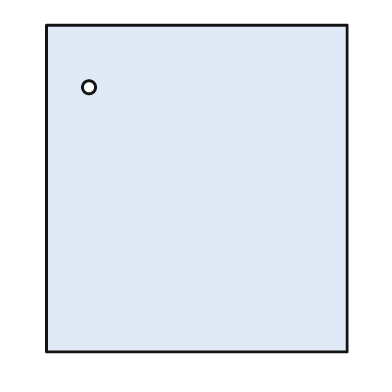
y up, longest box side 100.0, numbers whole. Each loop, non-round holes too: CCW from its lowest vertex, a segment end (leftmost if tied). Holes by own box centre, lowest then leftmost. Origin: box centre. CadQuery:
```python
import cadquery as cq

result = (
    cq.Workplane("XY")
    .moveTo(-46.0, -50.0)
    .lineTo(46.0, -50.0)
    .lineTo(46.0, 50.0)
    .lineTo(-46.0, 50.0)
    .close()
    .moveTo(-33.0, 31.0)
    .circle(2.0)
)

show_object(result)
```